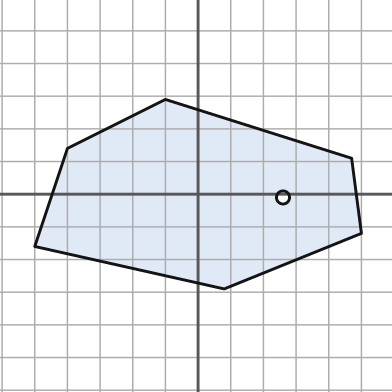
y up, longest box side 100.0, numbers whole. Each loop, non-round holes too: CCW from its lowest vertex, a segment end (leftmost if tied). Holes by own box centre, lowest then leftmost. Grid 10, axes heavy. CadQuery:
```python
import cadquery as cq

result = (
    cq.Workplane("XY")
    .moveTo(8.0, -29.0)
    .lineTo(50.0, -12.0)
    .lineTo(47.0, 11.0)
    .lineTo(-10.0, 29.0)
    .lineTo(-40.0, 14.0)
    .lineTo(-50.0, -16.0)
    .close()
    .moveTo(26.0, -1.0)
    .circle(2.0)
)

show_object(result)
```